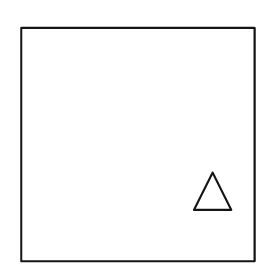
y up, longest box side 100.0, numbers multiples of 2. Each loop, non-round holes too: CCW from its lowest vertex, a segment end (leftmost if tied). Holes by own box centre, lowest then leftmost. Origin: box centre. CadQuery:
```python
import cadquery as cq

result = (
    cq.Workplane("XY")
    .moveTo(-50.0, -50.0)
    .lineTo(50.0, -50.0)
    .lineTo(50.0, 50.0)
    .lineTo(-50.0, 50.0)
    .close()
    .moveTo(24.0, -28.0)
    .lineTo(40.0, -28.0)
    .lineTo(32.0, -12.0)
    .close()
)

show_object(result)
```